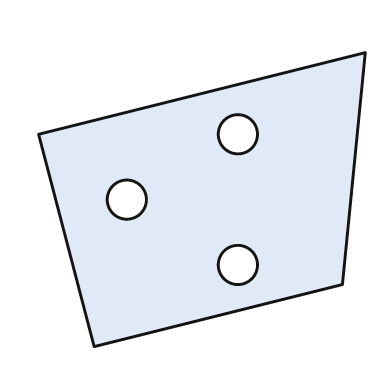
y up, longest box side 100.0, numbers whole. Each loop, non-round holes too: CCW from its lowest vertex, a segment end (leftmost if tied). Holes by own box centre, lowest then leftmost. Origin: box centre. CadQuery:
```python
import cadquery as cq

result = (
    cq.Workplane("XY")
    .moveTo(-33.0, -45.0)
    .lineTo(43.0, -26.0)
    .lineTo(50.0, 45.0)
    .lineTo(-50.0, 20.0)
    .close()
    .moveTo(11.0, -20.0)
    .circle(6.0)
    .moveTo(-23.0, 0.0)
    .circle(6.0)
    .moveTo(11.0, 20.0)
    .circle(6.0)
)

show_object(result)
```